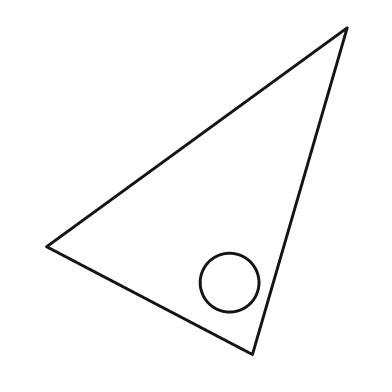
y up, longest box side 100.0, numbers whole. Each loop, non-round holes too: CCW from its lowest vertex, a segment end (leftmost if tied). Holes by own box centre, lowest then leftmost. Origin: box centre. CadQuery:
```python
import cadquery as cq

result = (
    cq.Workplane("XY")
    .moveTo(17.0, -50.0)
    .lineTo(46.0, 50.0)
    .lineTo(-46.0, -17.0)
    .close()
    .moveTo(10.0, -28.0)
    .circle(9.0)
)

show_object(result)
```